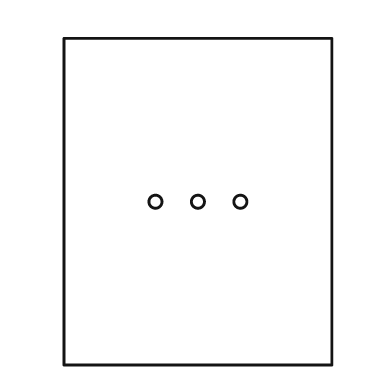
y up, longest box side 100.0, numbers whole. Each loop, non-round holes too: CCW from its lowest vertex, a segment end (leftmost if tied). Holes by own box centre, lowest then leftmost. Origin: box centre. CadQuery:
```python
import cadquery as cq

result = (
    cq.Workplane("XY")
    .moveTo(-41.0, -50.0)
    .lineTo(41.0, -50.0)
    .lineTo(41.0, 50.0)
    .lineTo(-41.0, 50.0)
    .close()
    .moveTo(-13.0, 0.0)
    .circle(2.0)
    .moveTo(0.0, 0.0)
    .circle(2.0)
    .moveTo(13.0, 0.0)
    .circle(2.0)
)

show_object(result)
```